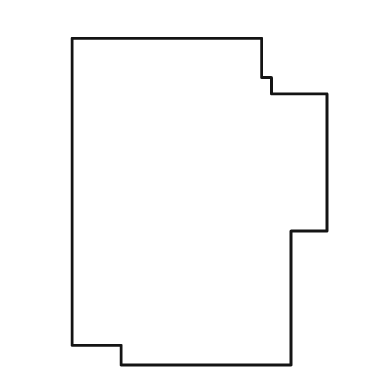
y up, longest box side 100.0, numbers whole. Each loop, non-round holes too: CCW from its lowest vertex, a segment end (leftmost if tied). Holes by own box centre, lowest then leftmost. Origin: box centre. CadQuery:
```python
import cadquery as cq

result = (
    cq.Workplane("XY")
    .moveTo(-24.0, -50.0)
    .lineTo(28.0, -50.0)
    .lineTo(28.0, -9.0)
    .lineTo(39.0, -9.0)
    .lineTo(39.0, 33.0)
    .lineTo(22.0, 33.0)
    .lineTo(22.0, 38.0)
    .lineTo(19.0, 38.0)
    .lineTo(19.0, 50.0)
    .lineTo(-39.0, 50.0)
    .lineTo(-39.0, -44.0)
    .lineTo(-24.0, -44.0)
    .close()
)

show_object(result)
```